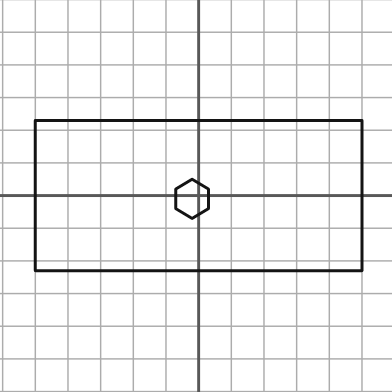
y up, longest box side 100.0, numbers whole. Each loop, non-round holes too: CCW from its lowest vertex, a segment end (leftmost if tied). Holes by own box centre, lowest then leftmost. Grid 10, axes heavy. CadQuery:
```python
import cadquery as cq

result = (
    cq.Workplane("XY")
    .moveTo(-50.0, -23.0)
    .lineTo(50.0, -23.0)
    .lineTo(50.0, 23.0)
    .lineTo(-50.0, 23.0)
    .close()
    .moveTo(-2.0, -7.0)
    .lineTo(3.0, -4.0)
    .lineTo(3.0, 2.0)
    .lineTo(-2.0, 5.0)
    .lineTo(-7.0, 2.0)
    .lineTo(-7.0, -4.0)
    .close()
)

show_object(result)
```